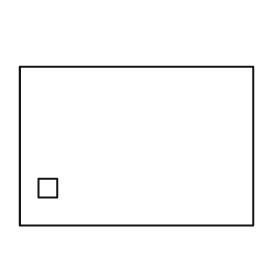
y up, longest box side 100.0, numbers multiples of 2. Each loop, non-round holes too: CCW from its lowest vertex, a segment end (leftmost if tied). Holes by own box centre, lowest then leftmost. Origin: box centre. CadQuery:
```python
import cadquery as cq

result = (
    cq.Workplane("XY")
    .moveTo(-50.0, -34.0)
    .lineTo(50.0, -34.0)
    .lineTo(50.0, 34.0)
    .lineTo(-50.0, 34.0)
    .close()
    .moveTo(-42.0, -22.0)
    .lineTo(-34.0, -22.0)
    .lineTo(-34.0, -14.0)
    .lineTo(-42.0, -14.0)
    .close()
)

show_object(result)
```